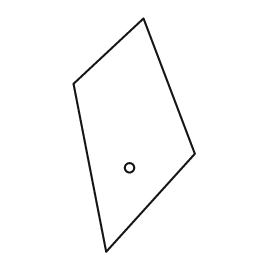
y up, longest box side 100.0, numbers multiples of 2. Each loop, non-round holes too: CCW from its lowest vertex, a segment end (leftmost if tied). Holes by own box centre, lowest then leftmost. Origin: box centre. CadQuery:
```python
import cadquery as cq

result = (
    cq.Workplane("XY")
    .moveTo(-12.0, -50.0)
    .lineTo(26.0, -8.0)
    .lineTo(4.0, 50.0)
    .lineTo(-26.0, 22.0)
    .close()
    .moveTo(-2.0, -14.0)
    .circle(2.0)
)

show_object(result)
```